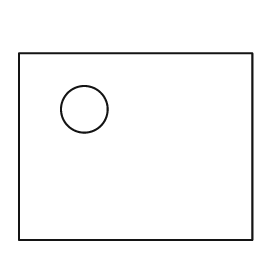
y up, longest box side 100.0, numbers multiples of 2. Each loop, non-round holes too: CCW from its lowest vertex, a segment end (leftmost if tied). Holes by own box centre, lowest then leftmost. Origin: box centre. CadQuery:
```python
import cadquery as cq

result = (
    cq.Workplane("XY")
    .moveTo(-50.0, -40.0)
    .lineTo(50.0, -40.0)
    .lineTo(50.0, 40.0)
    .lineTo(-50.0, 40.0)
    .close()
    .moveTo(-22.0, 16.0)
    .circle(10.0)
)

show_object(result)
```